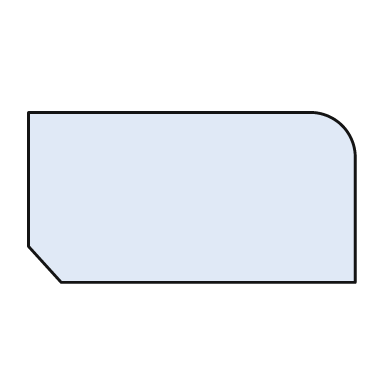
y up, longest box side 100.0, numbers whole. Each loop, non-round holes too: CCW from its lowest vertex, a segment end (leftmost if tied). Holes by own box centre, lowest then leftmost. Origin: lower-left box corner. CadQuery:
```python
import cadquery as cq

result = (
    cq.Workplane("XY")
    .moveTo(10.0, 0.0)
    .lineTo(100.0, 0.0)
    .lineTo(100.0, 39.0)
    .threePointArc((96.0, 48.0), (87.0, 52.0))
    .lineTo(0.0, 52.0)
    .lineTo(0.0, 11.0)
    .close()
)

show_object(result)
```